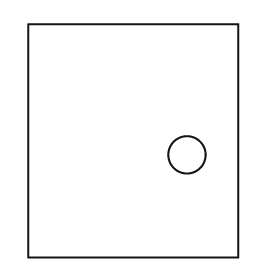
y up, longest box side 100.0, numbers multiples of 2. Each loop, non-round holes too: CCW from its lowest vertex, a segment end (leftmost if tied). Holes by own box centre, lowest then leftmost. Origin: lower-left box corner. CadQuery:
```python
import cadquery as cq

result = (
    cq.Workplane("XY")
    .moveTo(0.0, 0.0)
    .lineTo(90.0, 0.0)
    .lineTo(90.0, 100.0)
    .lineTo(0.0, 100.0)
    .close()
    .moveTo(68.0, 44.0)
    .circle(8.0)
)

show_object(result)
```